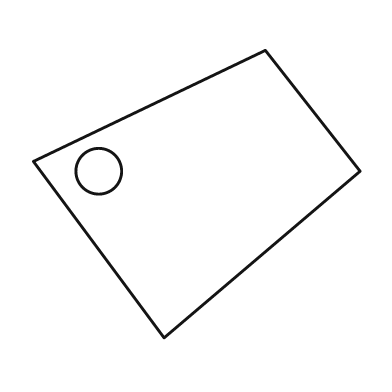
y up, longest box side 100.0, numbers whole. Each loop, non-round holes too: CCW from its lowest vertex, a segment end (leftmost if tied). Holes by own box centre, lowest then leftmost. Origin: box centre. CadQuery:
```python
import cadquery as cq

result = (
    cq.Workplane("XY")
    .moveTo(-10.0, -44.0)
    .lineTo(50.0, 7.0)
    .lineTo(21.0, 44.0)
    .lineTo(-50.0, 10.0)
    .close()
    .moveTo(-30.0, 7.0)
    .circle(7.0)
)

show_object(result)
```